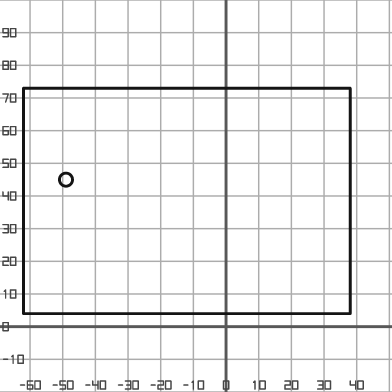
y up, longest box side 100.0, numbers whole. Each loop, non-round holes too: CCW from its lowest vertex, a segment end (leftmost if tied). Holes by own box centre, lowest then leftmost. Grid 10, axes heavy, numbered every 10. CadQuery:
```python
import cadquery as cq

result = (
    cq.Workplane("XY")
    .moveTo(-62.0, 4.0)
    .lineTo(38.0, 4.0)
    .lineTo(38.0, 73.0)
    .lineTo(-62.0, 73.0)
    .close()
    .moveTo(-49.0, 45.0)
    .circle(2.0)
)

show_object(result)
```